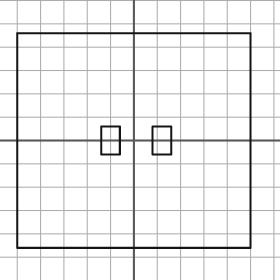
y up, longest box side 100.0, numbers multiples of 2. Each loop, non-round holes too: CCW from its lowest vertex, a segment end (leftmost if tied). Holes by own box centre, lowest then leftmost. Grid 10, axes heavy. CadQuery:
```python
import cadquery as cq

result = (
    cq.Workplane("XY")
    .moveTo(-50.0, -46.0)
    .lineTo(50.0, -46.0)
    .lineTo(50.0, 46.0)
    .lineTo(-50.0, 46.0)
    .close()
    .moveTo(-14.0, -6.0)
    .lineTo(-6.0, -6.0)
    .lineTo(-6.0, 6.0)
    .lineTo(-14.0, 6.0)
    .close()
    .moveTo(8.0, -6.0)
    .lineTo(16.0, -6.0)
    .lineTo(16.0, 6.0)
    .lineTo(8.0, 6.0)
    .close()
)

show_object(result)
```